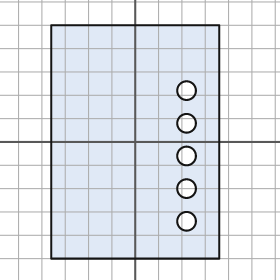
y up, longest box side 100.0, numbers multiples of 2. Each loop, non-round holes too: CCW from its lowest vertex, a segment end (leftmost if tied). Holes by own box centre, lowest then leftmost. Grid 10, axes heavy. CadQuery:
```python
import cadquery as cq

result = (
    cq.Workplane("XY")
    .moveTo(-36.0, -50.0)
    .lineTo(36.0, -50.0)
    .lineTo(36.0, 50.0)
    .lineTo(-36.0, 50.0)
    .close()
    .moveTo(22.0, -34.0)
    .circle(4.0)
    .moveTo(22.0, -20.0)
    .circle(4.0)
    .moveTo(22.0, -6.0)
    .circle(4.0)
    .moveTo(22.0, 8.0)
    .circle(4.0)
    .moveTo(22.0, 22.0)
    .circle(4.0)
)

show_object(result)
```